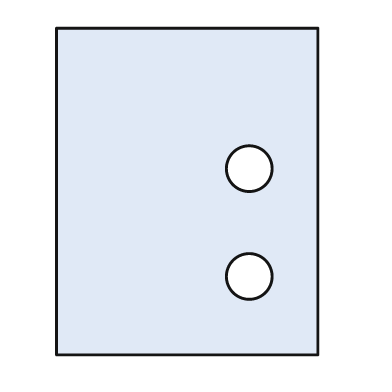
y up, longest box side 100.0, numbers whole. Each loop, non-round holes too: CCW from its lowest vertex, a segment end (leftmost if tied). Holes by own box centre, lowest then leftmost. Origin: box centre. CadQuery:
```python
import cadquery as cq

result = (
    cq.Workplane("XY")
    .moveTo(-40.0, -50.0)
    .lineTo(40.0, -50.0)
    .lineTo(40.0, 50.0)
    .lineTo(-40.0, 50.0)
    .close()
    .moveTo(19.0, -26.0)
    .circle(7.0)
    .moveTo(19.0, 7.0)
    .circle(7.0)
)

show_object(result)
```